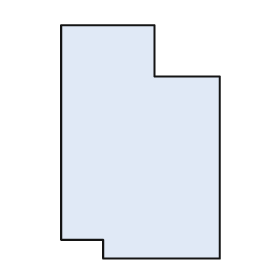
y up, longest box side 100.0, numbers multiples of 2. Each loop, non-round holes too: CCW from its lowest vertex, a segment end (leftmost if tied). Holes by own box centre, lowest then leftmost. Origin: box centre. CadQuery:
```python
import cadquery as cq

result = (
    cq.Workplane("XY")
    .moveTo(-16.0, -50.0)
    .lineTo(34.0, -50.0)
    .lineTo(34.0, 28.0)
    .lineTo(6.0, 28.0)
    .lineTo(6.0, 50.0)
    .lineTo(-34.0, 50.0)
    .lineTo(-34.0, -42.0)
    .lineTo(-16.0, -42.0)
    .close()
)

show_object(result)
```